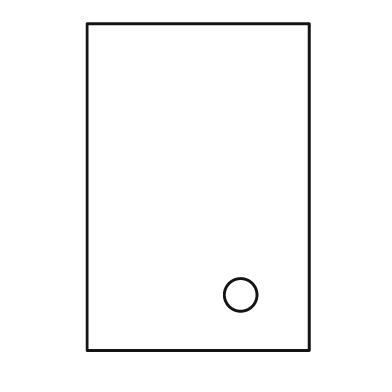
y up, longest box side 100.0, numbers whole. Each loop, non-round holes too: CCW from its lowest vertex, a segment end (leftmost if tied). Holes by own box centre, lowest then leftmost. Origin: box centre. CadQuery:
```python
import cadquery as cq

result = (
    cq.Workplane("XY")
    .moveTo(-34.0, -50.0)
    .lineTo(34.0, -50.0)
    .lineTo(34.0, 50.0)
    .lineTo(-34.0, 50.0)
    .close()
    .moveTo(13.0, -33.0)
    .circle(5.0)
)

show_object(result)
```